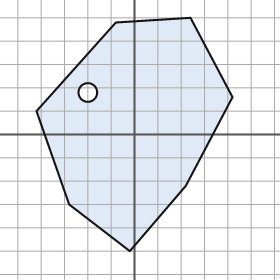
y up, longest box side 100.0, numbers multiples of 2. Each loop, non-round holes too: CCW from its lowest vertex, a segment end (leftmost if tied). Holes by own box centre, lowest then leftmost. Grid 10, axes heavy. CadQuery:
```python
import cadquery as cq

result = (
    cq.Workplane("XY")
    .moveTo(-2.0, -50.0)
    .lineTo(22.0, -22.0)
    .lineTo(42.0, 16.0)
    .lineTo(24.0, 50.0)
    .lineTo(-8.0, 48.0)
    .lineTo(-42.0, 10.0)
    .lineTo(-28.0, -30.0)
    .close()
    .moveTo(-20.0, 18.0)
    .circle(4.0)
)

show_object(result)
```